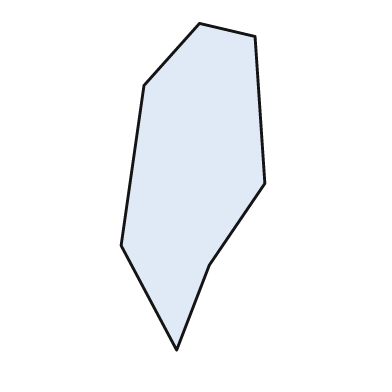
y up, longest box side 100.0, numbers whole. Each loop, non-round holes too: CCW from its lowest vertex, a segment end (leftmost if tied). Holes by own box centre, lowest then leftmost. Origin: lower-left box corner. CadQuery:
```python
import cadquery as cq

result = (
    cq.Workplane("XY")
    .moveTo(17.0, 0.0)
    .lineTo(27.0, 26.0)
    .lineTo(44.0, 51.0)
    .lineTo(41.0, 96.0)
    .lineTo(24.0, 100.0)
    .lineTo(7.0, 81.0)
    .lineTo(0.0, 32.0)
    .close()
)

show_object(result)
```